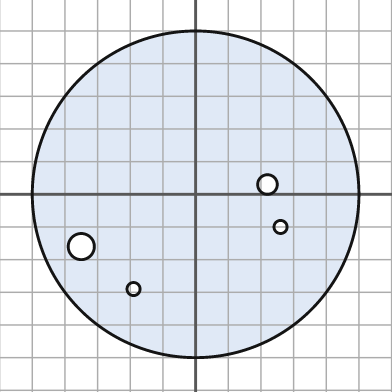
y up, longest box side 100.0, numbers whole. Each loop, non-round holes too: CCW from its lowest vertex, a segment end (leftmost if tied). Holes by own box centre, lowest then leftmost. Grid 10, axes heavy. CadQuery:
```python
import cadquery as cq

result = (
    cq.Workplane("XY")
    .moveTo(0.0, 0.0)
    .circle(50.0)
    .moveTo(-19.0, -29.0)
    .circle(2.0)
    .moveTo(-35.0, -16.0)
    .circle(4.0)
    .moveTo(26.0, -10.0)
    .circle(2.0)
    .moveTo(22.0, 3.0)
    .circle(3.0)
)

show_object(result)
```